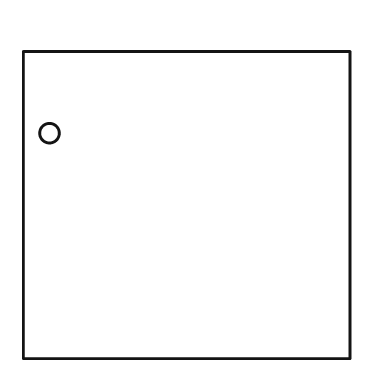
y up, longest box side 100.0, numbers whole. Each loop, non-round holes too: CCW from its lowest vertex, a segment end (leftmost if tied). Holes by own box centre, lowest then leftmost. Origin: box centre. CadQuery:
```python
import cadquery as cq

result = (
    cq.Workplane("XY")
    .moveTo(-50.0, -47.0)
    .lineTo(50.0, -47.0)
    .lineTo(50.0, 47.0)
    .lineTo(-50.0, 47.0)
    .close()
    .moveTo(-42.0, 22.0)
    .circle(3.0)
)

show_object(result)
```